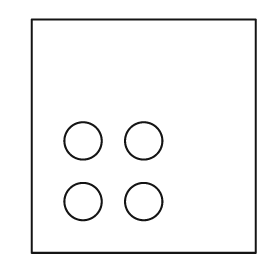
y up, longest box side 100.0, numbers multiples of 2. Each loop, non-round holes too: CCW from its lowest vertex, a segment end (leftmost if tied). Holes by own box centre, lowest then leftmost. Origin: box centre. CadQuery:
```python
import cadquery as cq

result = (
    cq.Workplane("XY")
    .moveTo(-48.0, -50.0)
    .lineTo(48.0, -50.0)
    .lineTo(48.0, 50.0)
    .lineTo(-48.0, 50.0)
    .close()
    .moveTo(-26.0, -28.0)
    .circle(8.0)
    .moveTo(0.0, -28.0)
    .circle(8.0)
    .moveTo(-26.0, -2.0)
    .circle(8.0)
    .moveTo(0.0, -2.0)
    .circle(8.0)
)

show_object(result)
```